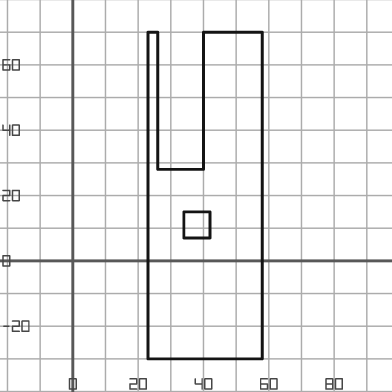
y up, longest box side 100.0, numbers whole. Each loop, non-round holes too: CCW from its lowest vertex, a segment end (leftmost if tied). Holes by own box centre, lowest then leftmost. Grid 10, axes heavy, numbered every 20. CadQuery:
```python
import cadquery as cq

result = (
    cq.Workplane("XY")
    .moveTo(23.0, -30.0)
    .lineTo(58.0, -30.0)
    .lineTo(58.0, 70.0)
    .lineTo(40.0, 70.0)
    .lineTo(40.0, 28.0)
    .lineTo(26.0, 28.0)
    .lineTo(26.0, 70.0)
    .lineTo(23.0, 70.0)
    .close()
    .moveTo(34.0, 7.0)
    .lineTo(42.0, 7.0)
    .lineTo(42.0, 15.0)
    .lineTo(34.0, 15.0)
    .close()
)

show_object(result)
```